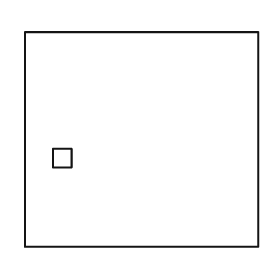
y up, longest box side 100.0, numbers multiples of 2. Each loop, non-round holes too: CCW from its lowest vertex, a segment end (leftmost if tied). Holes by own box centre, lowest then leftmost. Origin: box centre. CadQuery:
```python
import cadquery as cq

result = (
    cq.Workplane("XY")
    .moveTo(-50.0, -46.0)
    .lineTo(50.0, -46.0)
    .lineTo(50.0, 46.0)
    .lineTo(-50.0, 46.0)
    .close()
    .moveTo(-38.0, -12.0)
    .lineTo(-30.0, -12.0)
    .lineTo(-30.0, -4.0)
    .lineTo(-38.0, -4.0)
    .close()
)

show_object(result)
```